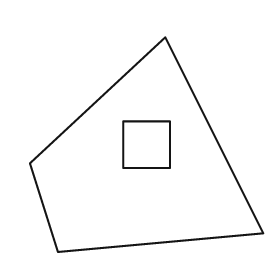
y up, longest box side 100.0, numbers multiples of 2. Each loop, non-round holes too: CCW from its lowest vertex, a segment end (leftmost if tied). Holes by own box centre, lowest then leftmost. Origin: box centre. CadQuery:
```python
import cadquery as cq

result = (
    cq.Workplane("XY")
    .moveTo(-38.0, -46.0)
    .lineTo(50.0, -38.0)
    .lineTo(8.0, 46.0)
    .lineTo(-50.0, -8.0)
    .close()
    .moveTo(-10.0, -10.0)
    .lineTo(10.0, -10.0)
    .lineTo(10.0, 10.0)
    .lineTo(-10.0, 10.0)
    .close()
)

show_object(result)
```